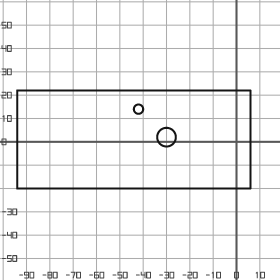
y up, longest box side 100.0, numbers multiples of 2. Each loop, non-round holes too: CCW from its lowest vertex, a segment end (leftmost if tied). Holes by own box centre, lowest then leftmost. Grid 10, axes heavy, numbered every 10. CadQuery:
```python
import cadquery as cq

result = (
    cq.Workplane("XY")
    .moveTo(-94.0, -20.0)
    .lineTo(6.0, -20.0)
    .lineTo(6.0, 22.0)
    .lineTo(-94.0, 22.0)
    .close()
    .moveTo(-30.0, 2.0)
    .circle(4.0)
    .moveTo(-42.0, 14.0)
    .circle(2.0)
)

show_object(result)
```